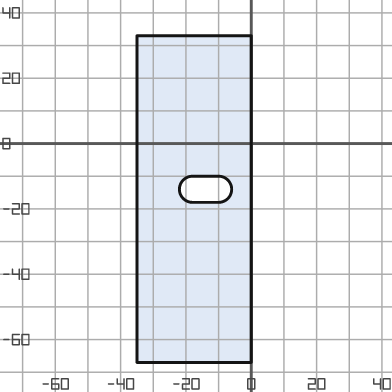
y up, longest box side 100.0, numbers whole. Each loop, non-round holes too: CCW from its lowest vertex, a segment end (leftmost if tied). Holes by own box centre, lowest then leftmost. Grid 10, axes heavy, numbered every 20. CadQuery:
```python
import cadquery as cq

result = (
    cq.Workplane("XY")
    .moveTo(-35.0, -67.0)
    .lineTo(0.0, -67.0)
    .lineTo(0.0, 33.0)
    .lineTo(-35.0, 33.0)
    .close()
    .moveTo(-18.0, -18.0)
    .lineTo(-10.0, -18.0)
    .threePointArc((-6.0, -14.0), (-10.0, -10.0))
    .lineTo(-18.0, -10.0)
    .threePointArc((-22.0, -14.0), (-18.0, -18.0))
    .close()
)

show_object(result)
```